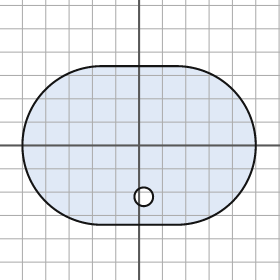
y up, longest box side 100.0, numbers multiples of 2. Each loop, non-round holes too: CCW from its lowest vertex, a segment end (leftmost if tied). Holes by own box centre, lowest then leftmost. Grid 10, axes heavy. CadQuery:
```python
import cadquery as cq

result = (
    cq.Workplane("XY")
    .moveTo(-16.0, -34.0)
    .lineTo(16.0, -34.0)
    .threePointArc((50.0, 0.0), (16.0, 34.0))
    .lineTo(-16.0, 34.0)
    .threePointArc((-50.0, 0.0), (-16.0, -34.0))
    .close()
    .moveTo(2.0, -22.0)
    .circle(4.0)
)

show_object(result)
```